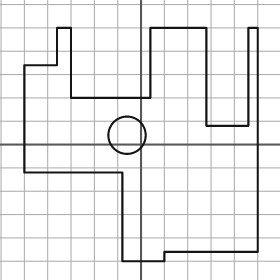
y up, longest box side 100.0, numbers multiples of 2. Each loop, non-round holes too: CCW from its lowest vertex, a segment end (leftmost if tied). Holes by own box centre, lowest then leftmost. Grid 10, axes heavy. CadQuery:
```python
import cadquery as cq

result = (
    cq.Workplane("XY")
    .moveTo(-8.0, -50.0)
    .lineTo(10.0, -50.0)
    .lineTo(10.0, -46.0)
    .lineTo(50.0, -46.0)
    .lineTo(50.0, 50.0)
    .lineTo(46.0, 50.0)
    .lineTo(46.0, 8.0)
    .lineTo(28.0, 8.0)
    .lineTo(28.0, 50.0)
    .lineTo(4.0, 50.0)
    .lineTo(4.0, 20.0)
    .lineTo(-30.0, 20.0)
    .lineTo(-30.0, 50.0)
    .lineTo(-36.0, 50.0)
    .lineTo(-36.0, 34.0)
    .lineTo(-50.0, 34.0)
    .lineTo(-50.0, -12.0)
    .lineTo(-8.0, -12.0)
    .close()
    .moveTo(-6.0, 4.0)
    .circle(8.0)
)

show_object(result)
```